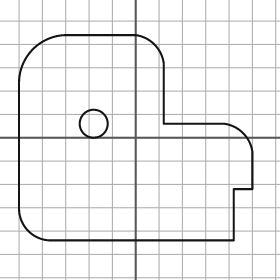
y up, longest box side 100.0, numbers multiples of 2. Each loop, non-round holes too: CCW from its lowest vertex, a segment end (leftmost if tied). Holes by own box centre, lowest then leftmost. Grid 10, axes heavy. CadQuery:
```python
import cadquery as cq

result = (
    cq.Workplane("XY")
    .moveTo(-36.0, -44.0)
    .lineTo(42.0, -44.0)
    .lineTo(42.0, -22.0)
    .lineTo(50.0, -22.0)
    .lineTo(50.0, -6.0)
    .threePointArc((46.0, 2.0), (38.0, 6.0))
    .lineTo(12.0, 6.0)
    .lineTo(12.0, 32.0)
    .threePointArc((8.0, 40.0), (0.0, 44.0))
    .lineTo(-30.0, 44.0)
    .threePointArc((-44.0, 38.0), (-50.0, 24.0))
    .lineTo(-50.0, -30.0)
    .threePointArc((-46.0, -40.0), (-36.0, -44.0))
    .close()
    .moveTo(-18.0, 6.0)
    .circle(6.0)
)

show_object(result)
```